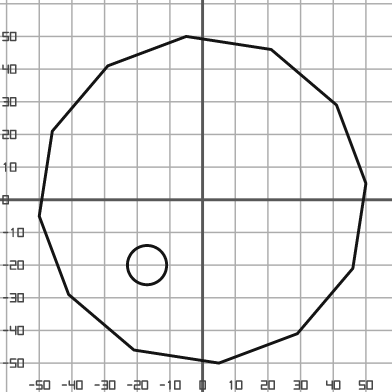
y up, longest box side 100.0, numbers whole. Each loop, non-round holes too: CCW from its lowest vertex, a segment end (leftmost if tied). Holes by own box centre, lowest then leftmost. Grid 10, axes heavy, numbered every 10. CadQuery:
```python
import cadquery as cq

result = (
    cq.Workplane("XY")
    .moveTo(5.0, -50.0)
    .lineTo(29.0, -41.0)
    .lineTo(46.0, -21.0)
    .lineTo(50.0, 5.0)
    .lineTo(41.0, 29.0)
    .lineTo(21.0, 46.0)
    .lineTo(-5.0, 50.0)
    .lineTo(-29.0, 41.0)
    .lineTo(-46.0, 21.0)
    .lineTo(-50.0, -5.0)
    .lineTo(-41.0, -29.0)
    .lineTo(-21.0, -46.0)
    .close()
    .moveTo(-17.0, -20.0)
    .circle(6.0)
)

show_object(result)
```